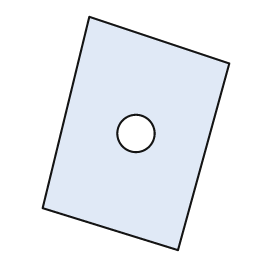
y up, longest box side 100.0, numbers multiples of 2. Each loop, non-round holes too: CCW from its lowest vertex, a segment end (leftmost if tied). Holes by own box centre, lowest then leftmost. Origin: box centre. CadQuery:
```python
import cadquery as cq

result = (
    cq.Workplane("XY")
    .moveTo(18.0, -50.0)
    .lineTo(40.0, 30.0)
    .lineTo(-20.0, 50.0)
    .lineTo(-40.0, -32.0)
    .close()
    .moveTo(0.0, 0.0)
    .circle(8.0)
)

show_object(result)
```